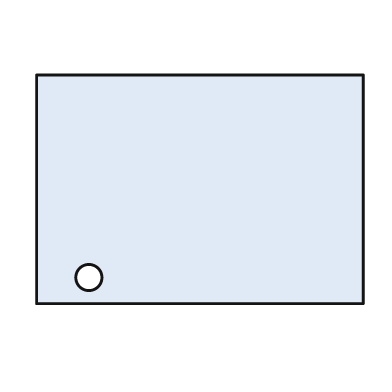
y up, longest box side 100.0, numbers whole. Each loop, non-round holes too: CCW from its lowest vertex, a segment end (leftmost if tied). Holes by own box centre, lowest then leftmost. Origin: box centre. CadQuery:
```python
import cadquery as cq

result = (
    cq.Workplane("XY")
    .moveTo(-50.0, -35.0)
    .lineTo(50.0, -35.0)
    .lineTo(50.0, 35.0)
    .lineTo(-50.0, 35.0)
    .close()
    .moveTo(-34.0, -27.0)
    .circle(4.0)
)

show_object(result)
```